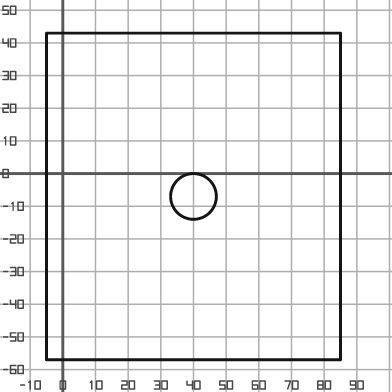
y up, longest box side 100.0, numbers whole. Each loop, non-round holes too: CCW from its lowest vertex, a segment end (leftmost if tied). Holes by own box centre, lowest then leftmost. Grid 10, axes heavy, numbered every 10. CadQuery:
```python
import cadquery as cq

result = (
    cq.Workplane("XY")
    .moveTo(-5.0, -57.0)
    .lineTo(85.0, -57.0)
    .lineTo(85.0, 43.0)
    .lineTo(-5.0, 43.0)
    .close()
    .moveTo(40.0, -7.0)
    .circle(7.0)
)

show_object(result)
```